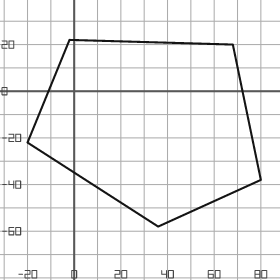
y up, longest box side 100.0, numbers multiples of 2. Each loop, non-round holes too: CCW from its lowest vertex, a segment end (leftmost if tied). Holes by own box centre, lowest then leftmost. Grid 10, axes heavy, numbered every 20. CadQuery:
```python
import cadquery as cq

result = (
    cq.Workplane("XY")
    .moveTo(36.0, -58.0)
    .lineTo(80.0, -38.0)
    .lineTo(68.0, 20.0)
    .lineTo(-2.0, 22.0)
    .lineTo(-20.0, -22.0)
    .close()
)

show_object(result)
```